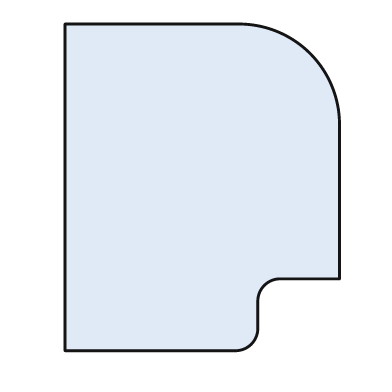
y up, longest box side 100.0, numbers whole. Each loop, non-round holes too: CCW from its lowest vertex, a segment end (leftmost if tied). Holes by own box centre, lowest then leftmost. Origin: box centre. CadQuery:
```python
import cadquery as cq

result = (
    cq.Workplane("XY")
    .moveTo(-42.0, -50.0)
    .lineTo(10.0, -50.0)
    .threePointArc((15.0, -48.0), (17.0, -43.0))
    .lineTo(17.0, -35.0)
    .threePointArc((19.0, -30.0), (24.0, -28.0))
    .lineTo(42.0, -28.0)
    .lineTo(42.0, 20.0)
    .threePointArc((33.0, 41.0), (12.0, 50.0))
    .lineTo(-42.0, 50.0)
    .close()
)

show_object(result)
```